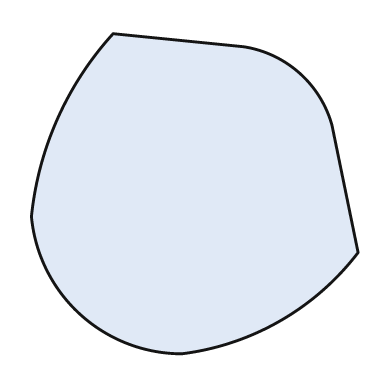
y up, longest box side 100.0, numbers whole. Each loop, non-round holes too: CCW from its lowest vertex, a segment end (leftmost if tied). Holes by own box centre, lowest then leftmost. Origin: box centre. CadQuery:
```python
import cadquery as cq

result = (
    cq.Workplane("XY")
    .moveTo(-4.0, -49.0)
    .threePointArc((26.0, -39.0), (50.0, -18.0))
    .lineTo(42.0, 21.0)
    .threePointArc((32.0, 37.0), (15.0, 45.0))
    .lineTo(-25.0, 49.0)
    .threePointArc((-42.0, 23.0), (-50.0, -7.0))
    .threePointArc((-35.0, -37.0), (-4.0, -49.0))
    .close()
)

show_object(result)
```